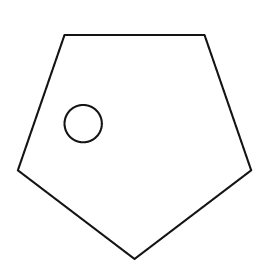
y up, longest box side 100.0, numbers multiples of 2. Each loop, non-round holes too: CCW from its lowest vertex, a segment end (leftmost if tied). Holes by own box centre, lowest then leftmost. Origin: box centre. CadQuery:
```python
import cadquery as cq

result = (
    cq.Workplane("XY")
    .moveTo(0.0, -48.0)
    .lineTo(50.0, -10.0)
    .lineTo(30.0, 48.0)
    .lineTo(-30.0, 48.0)
    .lineTo(-50.0, -10.0)
    .close()
    .moveTo(-22.0, 10.0)
    .circle(8.0)
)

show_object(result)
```